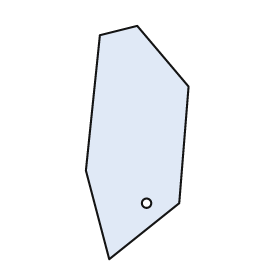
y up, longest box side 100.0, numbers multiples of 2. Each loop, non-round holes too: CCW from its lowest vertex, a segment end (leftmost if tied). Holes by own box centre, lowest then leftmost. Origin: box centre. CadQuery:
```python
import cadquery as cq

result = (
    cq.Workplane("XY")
    .moveTo(-12.0, -50.0)
    .lineTo(18.0, -26.0)
    .lineTo(22.0, 24.0)
    .lineTo(0.0, 50.0)
    .lineTo(-16.0, 46.0)
    .lineTo(-22.0, -12.0)
    .close()
    .moveTo(4.0, -26.0)
    .circle(2.0)
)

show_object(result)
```